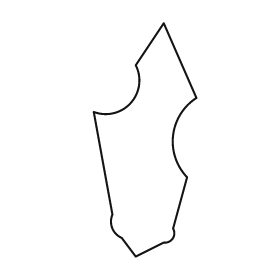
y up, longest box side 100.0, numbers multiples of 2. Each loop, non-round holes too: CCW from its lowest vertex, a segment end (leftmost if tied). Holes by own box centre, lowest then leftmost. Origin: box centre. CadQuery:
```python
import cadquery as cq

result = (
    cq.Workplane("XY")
    .moveTo(-4.0, -50.0)
    .lineTo(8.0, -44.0)
    .threePointArc((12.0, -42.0), (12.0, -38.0))
    .lineTo(18.0, -16.0)
    .threePointArc((12.0, 2.0), (22.0, 18.0))
    .lineTo(8.0, 50.0)
    .lineTo(-4.0, 32.0)
    .threePointArc((-6.0, 16.0), (-22.0, 12.0))
    .lineTo(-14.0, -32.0)
    .threePointArc((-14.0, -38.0), (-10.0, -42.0))
    .close()
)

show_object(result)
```